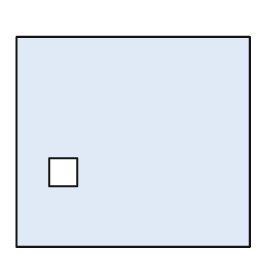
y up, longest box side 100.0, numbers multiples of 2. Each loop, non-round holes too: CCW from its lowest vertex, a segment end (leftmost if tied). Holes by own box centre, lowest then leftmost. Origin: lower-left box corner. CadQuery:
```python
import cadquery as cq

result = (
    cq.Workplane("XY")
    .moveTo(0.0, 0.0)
    .lineTo(100.0, 0.0)
    .lineTo(100.0, 90.0)
    .lineTo(0.0, 90.0)
    .close()
    .moveTo(14.0, 26.0)
    .lineTo(26.0, 26.0)
    .lineTo(26.0, 38.0)
    .lineTo(14.0, 38.0)
    .close()
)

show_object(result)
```